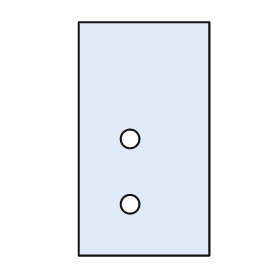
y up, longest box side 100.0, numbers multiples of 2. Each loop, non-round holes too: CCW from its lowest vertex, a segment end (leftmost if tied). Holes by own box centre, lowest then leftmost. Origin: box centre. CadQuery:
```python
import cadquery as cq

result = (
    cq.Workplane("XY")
    .moveTo(-28.0, -50.0)
    .lineTo(28.0, -50.0)
    .lineTo(28.0, 50.0)
    .lineTo(-28.0, 50.0)
    .close()
    .moveTo(-6.0, -28.0)
    .circle(4.0)
    .moveTo(-6.0, 0.0)
    .circle(4.0)
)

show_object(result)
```